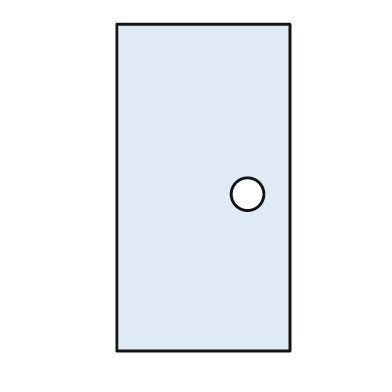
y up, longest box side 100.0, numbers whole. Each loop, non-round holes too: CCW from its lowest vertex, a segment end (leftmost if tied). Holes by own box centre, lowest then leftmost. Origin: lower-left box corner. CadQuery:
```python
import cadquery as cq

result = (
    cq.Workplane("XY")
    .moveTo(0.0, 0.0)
    .lineTo(53.0, 0.0)
    .lineTo(53.0, 100.0)
    .lineTo(0.0, 100.0)
    .close()
    .moveTo(40.0, 48.0)
    .circle(5.0)
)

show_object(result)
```